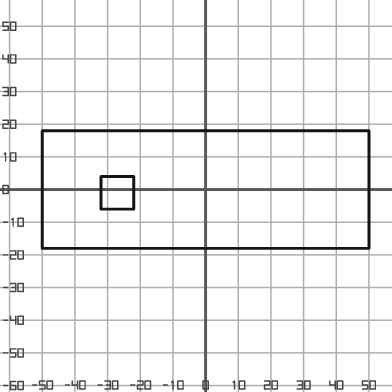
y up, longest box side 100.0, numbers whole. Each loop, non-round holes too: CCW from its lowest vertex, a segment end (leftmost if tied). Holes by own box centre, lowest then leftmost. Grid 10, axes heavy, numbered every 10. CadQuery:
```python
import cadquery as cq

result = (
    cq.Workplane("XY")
    .moveTo(-50.0, -18.0)
    .lineTo(50.0, -18.0)
    .lineTo(50.0, 18.0)
    .lineTo(-50.0, 18.0)
    .close()
    .moveTo(-32.0, -6.0)
    .lineTo(-22.0, -6.0)
    .lineTo(-22.0, 4.0)
    .lineTo(-32.0, 4.0)
    .close()
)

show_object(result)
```